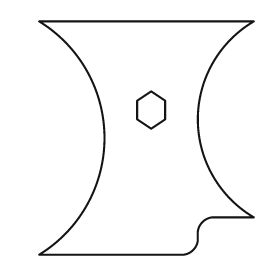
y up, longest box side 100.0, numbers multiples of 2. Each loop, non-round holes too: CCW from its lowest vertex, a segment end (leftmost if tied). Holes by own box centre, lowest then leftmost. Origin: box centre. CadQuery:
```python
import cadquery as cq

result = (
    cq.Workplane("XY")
    .moveTo(-46.0, -50.0)
    .lineTo(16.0, -50.0)
    .threePointArc((20.0, -48.0), (22.0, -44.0))
    .lineTo(22.0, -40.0)
    .threePointArc((24.0, -36.0), (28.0, -34.0))
    .lineTo(46.0, -34.0)
    .threePointArc((22.0, 8.0), (46.0, 50.0))
    .lineTo(-46.0, 50.0)
    .threePointArc((-18.0, 0.0), (-46.0, -50.0))
    .close()
    .moveTo(2.0, 4.0)
    .lineTo(8.0, 8.0)
    .lineTo(8.0, 16.0)
    .lineTo(2.0, 20.0)
    .lineTo(-4.0, 16.0)
    .lineTo(-4.0, 8.0)
    .close()
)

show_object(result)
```